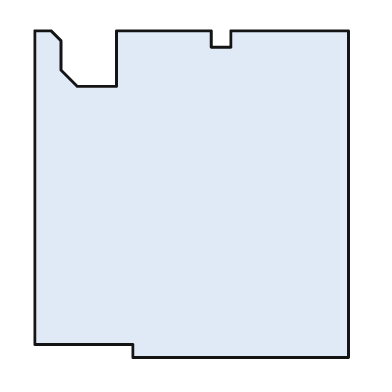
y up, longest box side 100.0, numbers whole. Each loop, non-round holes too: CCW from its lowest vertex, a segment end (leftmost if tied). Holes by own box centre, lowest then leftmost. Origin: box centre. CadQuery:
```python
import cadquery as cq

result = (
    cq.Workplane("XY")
    .moveTo(-18.0, -50.0)
    .lineTo(48.0, -50.0)
    .lineTo(48.0, 50.0)
    .lineTo(12.0, 50.0)
    .lineTo(12.0, 45.0)
    .lineTo(6.0, 45.0)
    .lineTo(6.0, 50.0)
    .lineTo(-23.0, 50.0)
    .lineTo(-23.0, 33.0)
    .lineTo(-35.0, 33.0)
    .lineTo(-40.0, 38.0)
    .lineTo(-40.0, 47.0)
    .lineTo(-43.0, 50.0)
    .lineTo(-48.0, 50.0)
    .lineTo(-48.0, -46.0)
    .lineTo(-18.0, -46.0)
    .close()
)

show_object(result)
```